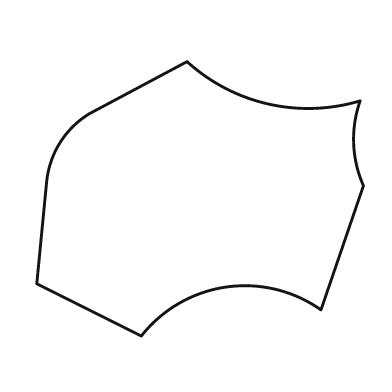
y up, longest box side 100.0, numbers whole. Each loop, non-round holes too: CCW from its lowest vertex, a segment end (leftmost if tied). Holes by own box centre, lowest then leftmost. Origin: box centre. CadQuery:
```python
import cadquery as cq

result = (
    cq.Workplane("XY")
    .moveTo(-18.0, -42.0)
    .threePointArc((8.0, -27.0), (37.0, -34.0))
    .lineTo(50.0, 4.0)
    .threePointArc((47.0, 17.0), (49.0, 30.0))
    .threePointArc((21.0, 29.0), (-4.0, 42.0))
    .lineTo(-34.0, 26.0)
    .threePointArc((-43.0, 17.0), (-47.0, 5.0))
    .lineTo(-50.0, -26.0)
    .close()
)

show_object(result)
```